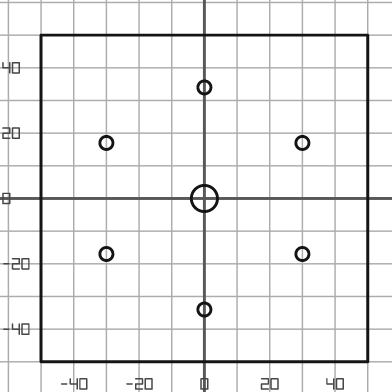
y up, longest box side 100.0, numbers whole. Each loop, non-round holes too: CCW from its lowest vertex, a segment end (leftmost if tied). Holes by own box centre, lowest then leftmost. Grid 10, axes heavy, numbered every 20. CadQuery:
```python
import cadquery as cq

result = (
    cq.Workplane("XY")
    .moveTo(-50.0, -50.0)
    .lineTo(50.0, -50.0)
    .lineTo(50.0, 50.0)
    .lineTo(-50.0, 50.0)
    .close()
    .moveTo(0.0, -34.0)
    .circle(2.0)
    .moveTo(-30.0, -17.0)
    .circle(2.0)
    .moveTo(30.0, -17.0)
    .circle(2.0)
    .moveTo(0.0, 0.0)
    .circle(4.0)
    .moveTo(-30.0, 17.0)
    .circle(2.0)
    .moveTo(30.0, 17.0)
    .circle(2.0)
    .moveTo(0.0, 34.0)
    .circle(2.0)
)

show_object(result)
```